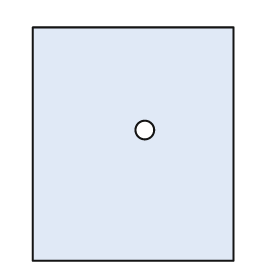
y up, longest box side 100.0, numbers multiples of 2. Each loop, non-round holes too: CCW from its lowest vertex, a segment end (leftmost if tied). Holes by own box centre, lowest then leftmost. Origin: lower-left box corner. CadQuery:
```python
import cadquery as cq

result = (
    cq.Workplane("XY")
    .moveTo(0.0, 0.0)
    .lineTo(86.0, 0.0)
    .lineTo(86.0, 100.0)
    .lineTo(0.0, 100.0)
    .close()
    .moveTo(48.0, 56.0)
    .circle(4.0)
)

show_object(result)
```